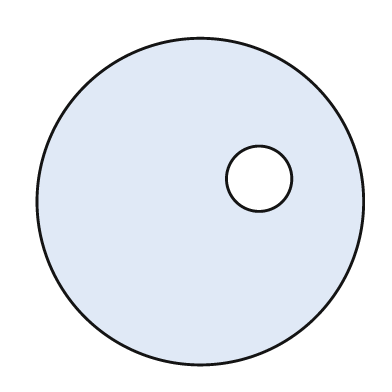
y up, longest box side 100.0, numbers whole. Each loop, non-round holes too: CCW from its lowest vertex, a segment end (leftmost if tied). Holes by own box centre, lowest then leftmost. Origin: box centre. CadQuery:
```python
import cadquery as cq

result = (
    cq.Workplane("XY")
    .moveTo(0.0, 0.0)
    .circle(50.0)
    .moveTo(18.0, 7.0)
    .circle(10.0)
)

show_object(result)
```